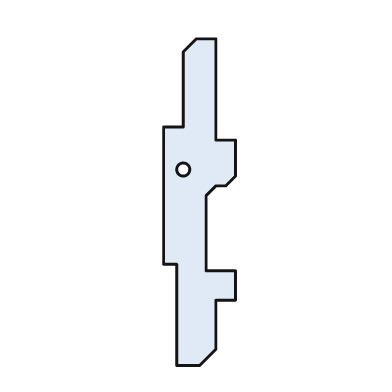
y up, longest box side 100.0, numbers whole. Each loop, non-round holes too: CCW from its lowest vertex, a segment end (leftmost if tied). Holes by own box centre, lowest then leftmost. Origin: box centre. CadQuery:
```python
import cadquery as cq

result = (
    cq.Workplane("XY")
    .moveTo(-7.0, -50.0)
    .lineTo(0.0, -50.0)
    .lineTo(5.0, -45.0)
    .lineTo(5.0, -30.0)
    .lineTo(11.0, -30.0)
    .lineTo(11.0, -21.0)
    .lineTo(2.0, -21.0)
    .lineTo(2.0, 2.0)
    .lineTo(5.0, 5.0)
    .lineTo(8.0, 5.0)
    .lineTo(11.0, 8.0)
    .lineTo(11.0, 19.0)
    .lineTo(5.0, 19.0)
    .lineTo(5.0, 50.0)
    .lineTo(-1.0, 50.0)
    .lineTo(-5.0, 46.0)
    .lineTo(-5.0, 23.0)
    .lineTo(-11.0, 23.0)
    .lineTo(-11.0, -19.0)
    .lineTo(-7.0, -19.0)
    .close()
    .moveTo(-5.0, 10.0)
    .circle(2.0)
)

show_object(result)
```